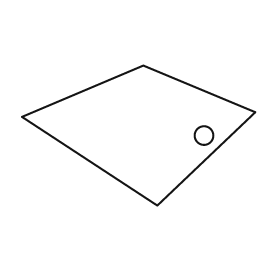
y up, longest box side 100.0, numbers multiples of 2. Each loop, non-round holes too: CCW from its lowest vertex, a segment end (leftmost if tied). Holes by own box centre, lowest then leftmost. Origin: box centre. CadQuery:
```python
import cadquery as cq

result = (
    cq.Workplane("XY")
    .moveTo(8.0, -30.0)
    .lineTo(50.0, 10.0)
    .lineTo(2.0, 30.0)
    .lineTo(-50.0, 8.0)
    .close()
    .moveTo(28.0, 0.0)
    .circle(4.0)
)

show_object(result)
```